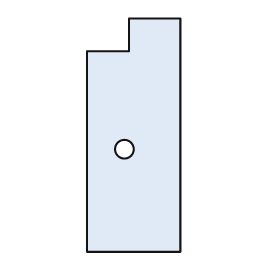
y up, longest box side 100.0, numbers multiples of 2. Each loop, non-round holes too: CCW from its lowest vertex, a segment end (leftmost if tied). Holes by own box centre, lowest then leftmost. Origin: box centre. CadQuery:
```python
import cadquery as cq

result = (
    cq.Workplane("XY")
    .moveTo(-20.0, -50.0)
    .lineTo(20.0, -50.0)
    .lineTo(20.0, 50.0)
    .lineTo(-2.0, 50.0)
    .lineTo(-2.0, 36.0)
    .lineTo(-20.0, 36.0)
    .close()
    .moveTo(-4.0, -6.0)
    .circle(4.0)
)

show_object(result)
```